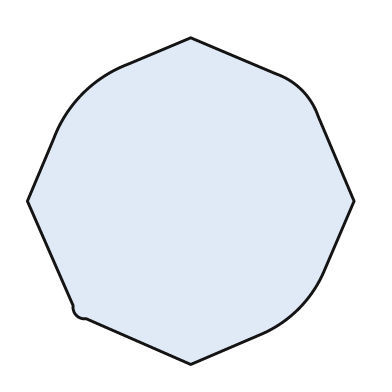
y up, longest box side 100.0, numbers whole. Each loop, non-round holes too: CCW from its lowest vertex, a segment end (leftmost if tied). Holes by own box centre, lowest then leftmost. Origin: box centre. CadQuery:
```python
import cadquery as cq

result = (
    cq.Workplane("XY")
    .moveTo(0.0, -50.0)
    .lineTo(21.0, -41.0)
    .threePointArc((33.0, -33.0), (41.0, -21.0))
    .lineTo(50.0, 0.0)
    .lineTo(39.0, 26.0)
    .threePointArc((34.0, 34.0), (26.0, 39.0))
    .lineTo(0.0, 50.0)
    .lineTo(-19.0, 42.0)
    .threePointArc((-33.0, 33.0), (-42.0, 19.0))
    .lineTo(-50.0, 0.0)
    .lineTo(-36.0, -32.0)
    .threePointArc((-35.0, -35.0), (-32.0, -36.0))
    .close()
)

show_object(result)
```